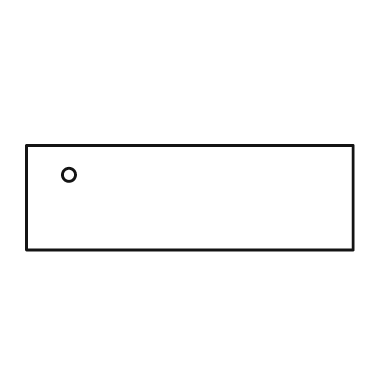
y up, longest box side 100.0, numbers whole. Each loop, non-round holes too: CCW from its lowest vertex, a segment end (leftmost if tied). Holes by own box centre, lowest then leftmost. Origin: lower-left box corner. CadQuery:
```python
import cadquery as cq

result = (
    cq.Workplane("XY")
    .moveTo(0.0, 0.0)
    .lineTo(100.0, 0.0)
    .lineTo(100.0, 32.0)
    .lineTo(0.0, 32.0)
    .close()
    .moveTo(13.0, 23.0)
    .circle(2.0)
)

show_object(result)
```